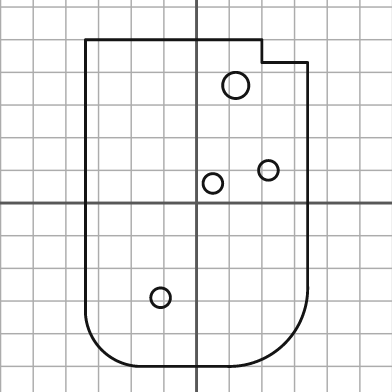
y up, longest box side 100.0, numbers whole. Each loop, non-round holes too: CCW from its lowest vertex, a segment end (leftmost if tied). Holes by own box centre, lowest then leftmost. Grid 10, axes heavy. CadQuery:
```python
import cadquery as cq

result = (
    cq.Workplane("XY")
    .moveTo(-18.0, -50.0)
    .lineTo(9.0, -50.0)
    .threePointArc((27.0, -43.0), (34.0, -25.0))
    .lineTo(34.0, 43.0)
    .lineTo(20.0, 43.0)
    .lineTo(20.0, 50.0)
    .lineTo(-34.0, 50.0)
    .lineTo(-34.0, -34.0)
    .threePointArc((-29.0, -45.0), (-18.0, -50.0))
    .close()
    .moveTo(-11.0, -29.0)
    .circle(3.0)
    .moveTo(5.0, 6.0)
    .circle(3.0)
    .moveTo(22.0, 10.0)
    .circle(3.0)
    .moveTo(12.0, 36.0)
    .circle(4.0)
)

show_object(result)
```